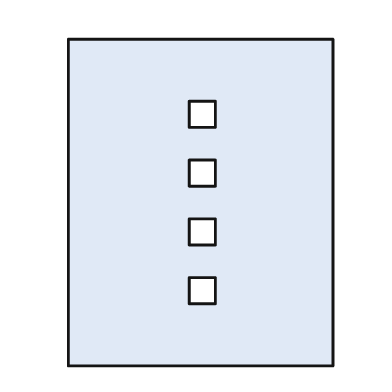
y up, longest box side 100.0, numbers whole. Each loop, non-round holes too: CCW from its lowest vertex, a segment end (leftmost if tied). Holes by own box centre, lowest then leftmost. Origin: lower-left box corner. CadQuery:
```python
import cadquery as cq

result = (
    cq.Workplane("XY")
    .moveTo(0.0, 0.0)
    .lineTo(81.0, 0.0)
    .lineTo(81.0, 100.0)
    .lineTo(0.0, 100.0)
    .close()
    .moveTo(37.0, 19.0)
    .lineTo(45.0, 19.0)
    .lineTo(45.0, 27.0)
    .lineTo(37.0, 27.0)
    .close()
    .moveTo(37.0, 37.0)
    .lineTo(45.0, 37.0)
    .lineTo(45.0, 45.0)
    .lineTo(37.0, 45.0)
    .close()
    .moveTo(37.0, 55.0)
    .lineTo(45.0, 55.0)
    .lineTo(45.0, 63.0)
    .lineTo(37.0, 63.0)
    .close()
    .moveTo(37.0, 73.0)
    .lineTo(45.0, 73.0)
    .lineTo(45.0, 81.0)
    .lineTo(37.0, 81.0)
    .close()
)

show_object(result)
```